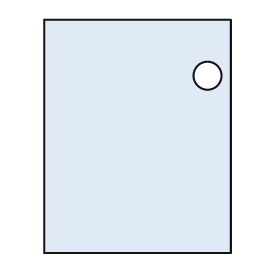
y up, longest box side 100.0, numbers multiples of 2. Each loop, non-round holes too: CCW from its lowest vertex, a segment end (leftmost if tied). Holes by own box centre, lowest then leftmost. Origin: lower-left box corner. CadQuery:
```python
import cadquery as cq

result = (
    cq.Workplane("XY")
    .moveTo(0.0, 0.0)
    .lineTo(80.0, 0.0)
    .lineTo(80.0, 100.0)
    .lineTo(0.0, 100.0)
    .close()
    .moveTo(70.0, 76.0)
    .circle(6.0)
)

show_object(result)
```